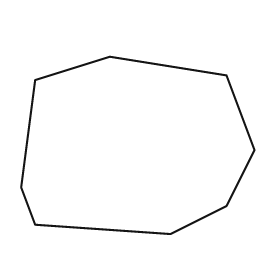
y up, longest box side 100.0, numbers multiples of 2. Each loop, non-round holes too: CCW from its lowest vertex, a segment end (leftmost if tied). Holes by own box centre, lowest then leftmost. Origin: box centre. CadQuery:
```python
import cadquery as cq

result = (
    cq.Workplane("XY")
    .moveTo(14.0, -38.0)
    .lineTo(38.0, -26.0)
    .lineTo(50.0, -2.0)
    .lineTo(38.0, 30.0)
    .lineTo(-12.0, 38.0)
    .lineTo(-44.0, 28.0)
    .lineTo(-50.0, -18.0)
    .lineTo(-44.0, -34.0)
    .close()
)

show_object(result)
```